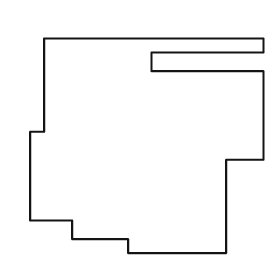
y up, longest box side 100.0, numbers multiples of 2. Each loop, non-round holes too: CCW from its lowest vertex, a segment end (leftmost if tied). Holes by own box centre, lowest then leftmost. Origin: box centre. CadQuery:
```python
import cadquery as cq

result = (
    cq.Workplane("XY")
    .moveTo(-8.0, -46.0)
    .lineTo(34.0, -46.0)
    .lineTo(34.0, -6.0)
    .lineTo(50.0, -6.0)
    .lineTo(50.0, 32.0)
    .lineTo(2.0, 32.0)
    .lineTo(2.0, 40.0)
    .lineTo(50.0, 40.0)
    .lineTo(50.0, 46.0)
    .lineTo(-44.0, 46.0)
    .lineTo(-44.0, 6.0)
    .lineTo(-50.0, 6.0)
    .lineTo(-50.0, -32.0)
    .lineTo(-32.0, -32.0)
    .lineTo(-32.0, -40.0)
    .lineTo(-8.0, -40.0)
    .close()
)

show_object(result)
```